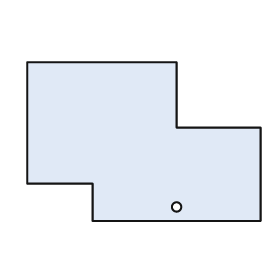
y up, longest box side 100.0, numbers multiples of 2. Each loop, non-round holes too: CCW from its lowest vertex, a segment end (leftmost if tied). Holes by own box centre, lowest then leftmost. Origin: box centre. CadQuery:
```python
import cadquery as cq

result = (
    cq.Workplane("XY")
    .moveTo(-22.0, -34.0)
    .lineTo(50.0, -34.0)
    .lineTo(50.0, 6.0)
    .lineTo(14.0, 6.0)
    .lineTo(14.0, 34.0)
    .lineTo(-50.0, 34.0)
    .lineTo(-50.0, -18.0)
    .lineTo(-22.0, -18.0)
    .close()
    .moveTo(14.0, -28.0)
    .circle(2.0)
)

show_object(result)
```